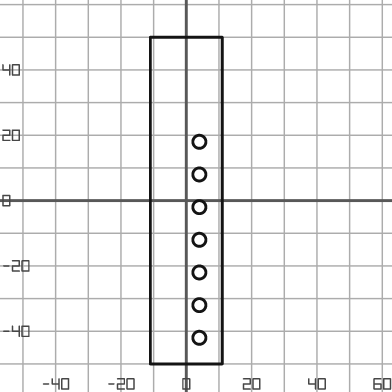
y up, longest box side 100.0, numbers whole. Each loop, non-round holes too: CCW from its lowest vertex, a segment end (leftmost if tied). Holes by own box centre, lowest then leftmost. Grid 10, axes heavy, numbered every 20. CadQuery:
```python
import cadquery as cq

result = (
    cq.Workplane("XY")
    .moveTo(-11.0, -50.0)
    .lineTo(11.0, -50.0)
    .lineTo(11.0, 50.0)
    .lineTo(-11.0, 50.0)
    .close()
    .moveTo(4.0, -42.0)
    .circle(2.0)
    .moveTo(4.0, -32.0)
    .circle(2.0)
    .moveTo(4.0, -22.0)
    .circle(2.0)
    .moveTo(4.0, -12.0)
    .circle(2.0)
    .moveTo(4.0, -2.0)
    .circle(2.0)
    .moveTo(4.0, 8.0)
    .circle(2.0)
    .moveTo(4.0, 18.0)
    .circle(2.0)
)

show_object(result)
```